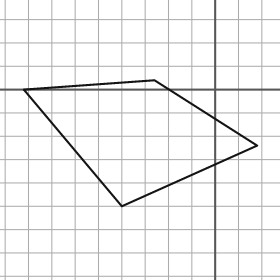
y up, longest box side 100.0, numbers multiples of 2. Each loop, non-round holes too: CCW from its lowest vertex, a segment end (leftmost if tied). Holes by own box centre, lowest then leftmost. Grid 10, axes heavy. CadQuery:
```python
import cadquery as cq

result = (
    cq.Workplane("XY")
    .moveTo(-40.0, -50.0)
    .lineTo(18.0, -24.0)
    .lineTo(-26.0, 4.0)
    .lineTo(-82.0, 0.0)
    .close()
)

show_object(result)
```